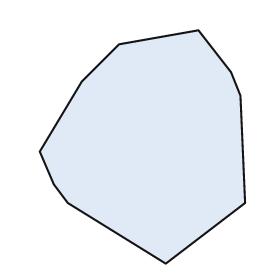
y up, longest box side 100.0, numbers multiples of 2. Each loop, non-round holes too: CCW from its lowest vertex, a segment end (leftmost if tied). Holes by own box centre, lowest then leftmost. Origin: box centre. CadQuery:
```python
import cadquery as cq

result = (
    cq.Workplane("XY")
    .moveTo(10.0, -50.0)
    .lineTo(44.0, -24.0)
    .lineTo(42.0, 22.0)
    .lineTo(38.0, 32.0)
    .lineTo(24.0, 50.0)
    .lineTo(-10.0, 44.0)
    .lineTo(-26.0, 28.0)
    .lineTo(-44.0, -2.0)
    .lineTo(-38.0, -16.0)
    .lineTo(-32.0, -24.0)
    .close()
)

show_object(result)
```